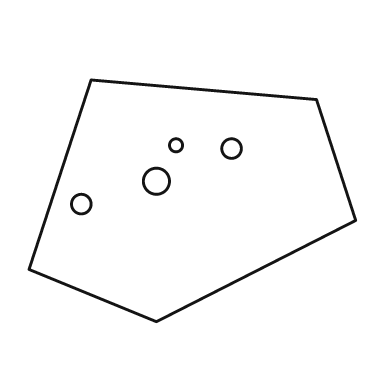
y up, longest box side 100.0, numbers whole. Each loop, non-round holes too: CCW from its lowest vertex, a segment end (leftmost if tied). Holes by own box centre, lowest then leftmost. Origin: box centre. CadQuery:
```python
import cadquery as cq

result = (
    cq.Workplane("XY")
    .moveTo(-11.0, -37.0)
    .lineTo(50.0, -6.0)
    .lineTo(38.0, 31.0)
    .lineTo(-31.0, 37.0)
    .lineTo(-50.0, -21.0)
    .close()
    .moveTo(-34.0, -1.0)
    .circle(3.0)
    .moveTo(-11.0, 6.0)
    .circle(4.0)
    .moveTo(12.0, 16.0)
    .circle(3.0)
    .moveTo(-5.0, 17.0)
    .circle(2.0)
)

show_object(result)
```